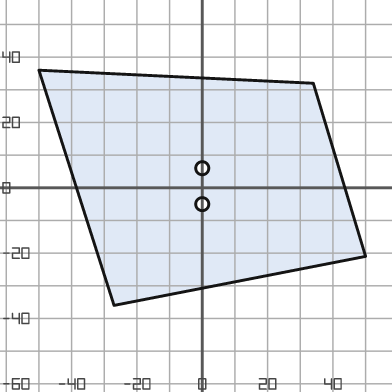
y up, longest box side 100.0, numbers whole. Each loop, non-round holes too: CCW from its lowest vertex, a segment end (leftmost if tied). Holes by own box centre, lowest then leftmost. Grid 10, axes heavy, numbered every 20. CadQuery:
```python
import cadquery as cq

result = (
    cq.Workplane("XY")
    .moveTo(-27.0, -36.0)
    .lineTo(50.0, -21.0)
    .lineTo(34.0, 32.0)
    .lineTo(-50.0, 36.0)
    .close()
    .moveTo(0.0, -5.0)
    .circle(2.0)
    .moveTo(0.0, 6.0)
    .circle(2.0)
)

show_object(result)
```